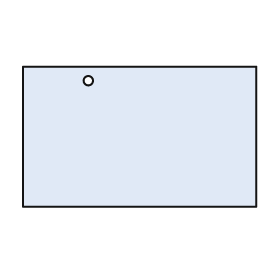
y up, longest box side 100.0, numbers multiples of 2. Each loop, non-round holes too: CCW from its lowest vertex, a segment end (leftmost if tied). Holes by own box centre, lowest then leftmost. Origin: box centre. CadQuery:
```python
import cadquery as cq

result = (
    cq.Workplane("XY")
    .moveTo(-50.0, -30.0)
    .lineTo(50.0, -30.0)
    .lineTo(50.0, 30.0)
    .lineTo(-50.0, 30.0)
    .close()
    .moveTo(-22.0, 24.0)
    .circle(2.0)
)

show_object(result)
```